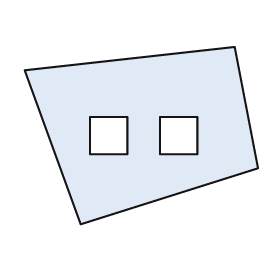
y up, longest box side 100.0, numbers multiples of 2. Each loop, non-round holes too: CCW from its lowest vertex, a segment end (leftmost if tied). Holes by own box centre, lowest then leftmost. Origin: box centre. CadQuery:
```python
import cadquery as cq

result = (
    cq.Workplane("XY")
    .moveTo(-26.0, -38.0)
    .lineTo(50.0, -14.0)
    .lineTo(40.0, 38.0)
    .lineTo(-50.0, 28.0)
    .close()
    .moveTo(-22.0, -8.0)
    .lineTo(-6.0, -8.0)
    .lineTo(-6.0, 8.0)
    .lineTo(-22.0, 8.0)
    .close()
    .moveTo(8.0, -8.0)
    .lineTo(24.0, -8.0)
    .lineTo(24.0, 8.0)
    .lineTo(8.0, 8.0)
    .close()
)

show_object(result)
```